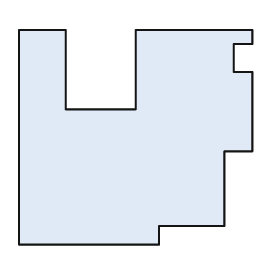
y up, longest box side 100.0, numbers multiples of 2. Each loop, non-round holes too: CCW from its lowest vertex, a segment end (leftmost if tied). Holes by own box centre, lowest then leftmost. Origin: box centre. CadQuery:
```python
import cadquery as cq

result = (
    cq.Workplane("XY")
    .moveTo(-50.0, -46.0)
    .lineTo(10.0, -46.0)
    .lineTo(10.0, -38.0)
    .lineTo(38.0, -38.0)
    .lineTo(38.0, -6.0)
    .lineTo(50.0, -6.0)
    .lineTo(50.0, 28.0)
    .lineTo(42.0, 28.0)
    .lineTo(42.0, 40.0)
    .lineTo(50.0, 40.0)
    .lineTo(50.0, 46.0)
    .lineTo(0.0, 46.0)
    .lineTo(0.0, 12.0)
    .lineTo(-30.0, 12.0)
    .lineTo(-30.0, 46.0)
    .lineTo(-50.0, 46.0)
    .close()
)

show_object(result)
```